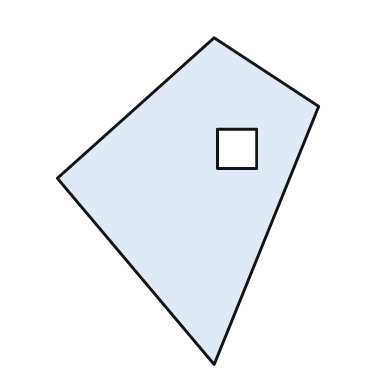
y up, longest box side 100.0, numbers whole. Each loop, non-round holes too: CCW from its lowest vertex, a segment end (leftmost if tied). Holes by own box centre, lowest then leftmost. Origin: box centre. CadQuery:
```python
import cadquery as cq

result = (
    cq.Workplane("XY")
    .moveTo(8.0, -50.0)
    .lineTo(40.0, 29.0)
    .lineTo(8.0, 50.0)
    .lineTo(-40.0, 7.0)
    .close()
    .moveTo(9.0, 10.0)
    .lineTo(21.0, 10.0)
    .lineTo(21.0, 22.0)
    .lineTo(9.0, 22.0)
    .close()
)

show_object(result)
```